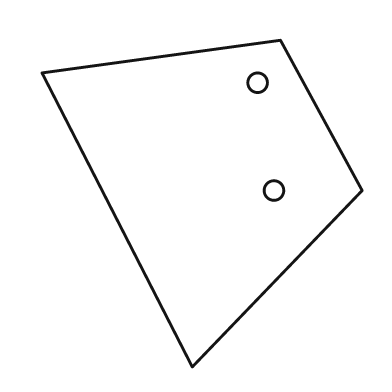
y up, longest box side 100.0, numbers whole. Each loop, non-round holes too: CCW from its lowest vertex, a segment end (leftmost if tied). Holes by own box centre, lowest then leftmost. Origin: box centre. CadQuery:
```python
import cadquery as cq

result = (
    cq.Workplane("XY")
    .moveTo(-3.0, -50.0)
    .lineTo(49.0, 4.0)
    .lineTo(24.0, 50.0)
    .lineTo(-49.0, 40.0)
    .close()
    .moveTo(22.0, 4.0)
    .circle(3.0)
    .moveTo(17.0, 37.0)
    .circle(3.0)
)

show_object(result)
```